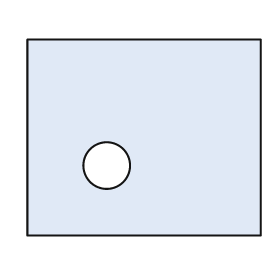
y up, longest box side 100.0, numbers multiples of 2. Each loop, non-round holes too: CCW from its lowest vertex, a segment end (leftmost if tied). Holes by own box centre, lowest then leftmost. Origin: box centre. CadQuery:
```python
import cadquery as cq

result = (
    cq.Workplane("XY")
    .moveTo(-50.0, -42.0)
    .lineTo(50.0, -42.0)
    .lineTo(50.0, 42.0)
    .lineTo(-50.0, 42.0)
    .close()
    .moveTo(-16.0, -12.0)
    .circle(10.0)
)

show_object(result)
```